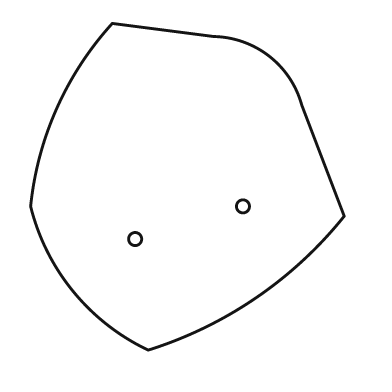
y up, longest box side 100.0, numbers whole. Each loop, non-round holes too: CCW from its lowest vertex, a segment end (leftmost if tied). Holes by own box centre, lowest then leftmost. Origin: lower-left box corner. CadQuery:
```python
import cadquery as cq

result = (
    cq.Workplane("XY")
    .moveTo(36.0, 0.0)
    .threePointArc((69.0, 16.0), (96.0, 41.0))
    .lineTo(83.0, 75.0)
    .threePointArc((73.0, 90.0), (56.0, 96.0))
    .lineTo(25.0, 100.0)
    .threePointArc((8.0, 74.0), (0.0, 44.0))
    .threePointArc((13.0, 18.0), (36.0, 0.0))
    .close()
    .moveTo(32.0, 34.0)
    .circle(2.0)
    .moveTo(65.0, 44.0)
    .circle(2.0)
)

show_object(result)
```